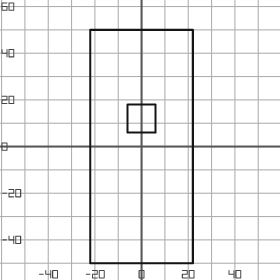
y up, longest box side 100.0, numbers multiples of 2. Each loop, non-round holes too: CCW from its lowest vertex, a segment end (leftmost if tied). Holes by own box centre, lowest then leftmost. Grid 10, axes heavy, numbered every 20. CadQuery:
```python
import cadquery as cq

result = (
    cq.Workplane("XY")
    .moveTo(-22.0, -50.0)
    .lineTo(22.0, -50.0)
    .lineTo(22.0, 50.0)
    .lineTo(-22.0, 50.0)
    .close()
    .moveTo(-6.0, 6.0)
    .lineTo(6.0, 6.0)
    .lineTo(6.0, 18.0)
    .lineTo(-6.0, 18.0)
    .close()
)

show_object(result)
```